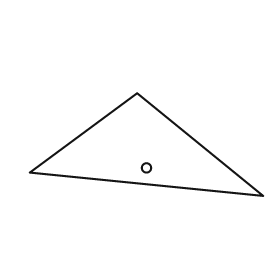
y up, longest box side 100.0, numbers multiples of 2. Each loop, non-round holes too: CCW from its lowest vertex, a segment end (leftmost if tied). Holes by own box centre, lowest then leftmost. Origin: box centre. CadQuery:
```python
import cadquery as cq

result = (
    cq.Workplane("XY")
    .moveTo(50.0, -22.0)
    .lineTo(-4.0, 22.0)
    .lineTo(-50.0, -12.0)
    .close()
    .moveTo(0.0, -10.0)
    .circle(2.0)
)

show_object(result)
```